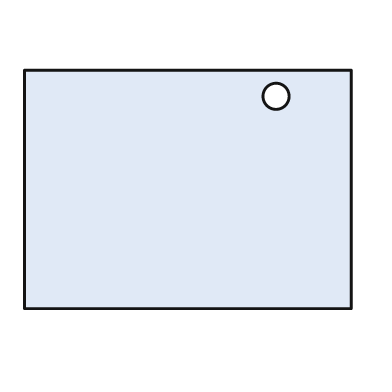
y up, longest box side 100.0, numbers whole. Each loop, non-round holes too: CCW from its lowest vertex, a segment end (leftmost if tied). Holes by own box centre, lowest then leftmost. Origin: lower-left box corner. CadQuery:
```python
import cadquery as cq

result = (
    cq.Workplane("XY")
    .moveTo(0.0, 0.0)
    .lineTo(100.0, 0.0)
    .lineTo(100.0, 73.0)
    .lineTo(0.0, 73.0)
    .close()
    .moveTo(77.0, 65.0)
    .circle(4.0)
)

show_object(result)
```